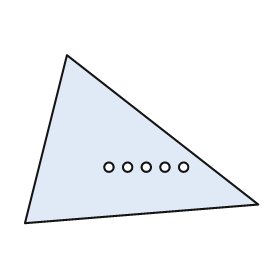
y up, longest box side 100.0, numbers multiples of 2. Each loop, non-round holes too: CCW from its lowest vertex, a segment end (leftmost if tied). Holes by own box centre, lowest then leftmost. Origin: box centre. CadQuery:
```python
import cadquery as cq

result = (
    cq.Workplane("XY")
    .moveTo(-50.0, -36.0)
    .lineTo(50.0, -28.0)
    .lineTo(-32.0, 36.0)
    .close()
    .moveTo(-14.0, -12.0)
    .circle(2.0)
    .moveTo(-6.0, -12.0)
    .circle(2.0)
    .moveTo(2.0, -12.0)
    .circle(2.0)
    .moveTo(10.0, -12.0)
    .circle(2.0)
    .moveTo(18.0, -12.0)
    .circle(2.0)
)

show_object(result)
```